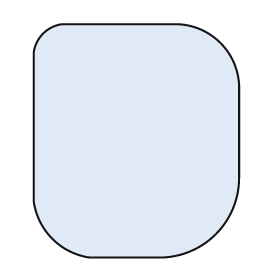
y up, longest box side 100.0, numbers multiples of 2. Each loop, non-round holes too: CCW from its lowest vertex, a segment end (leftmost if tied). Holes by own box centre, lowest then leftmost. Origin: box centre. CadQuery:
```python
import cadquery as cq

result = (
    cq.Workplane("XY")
    .moveTo(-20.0, -50.0)
    .lineTo(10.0, -50.0)
    .threePointArc((34.0, -40.0), (44.0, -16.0))
    .lineTo(44.0, 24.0)
    .threePointArc((36.0, 42.0), (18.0, 50.0))
    .lineTo(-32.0, 50.0)
    .threePointArc((-40.0, 46.0), (-44.0, 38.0))
    .lineTo(-44.0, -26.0)
    .threePointArc((-36.0, -42.0), (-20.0, -50.0))
    .close()
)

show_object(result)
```